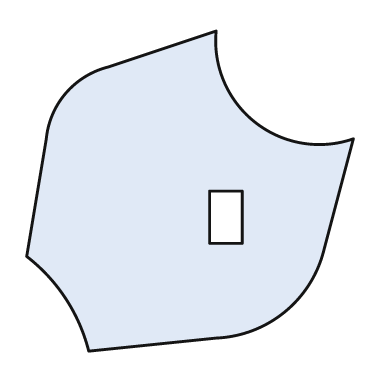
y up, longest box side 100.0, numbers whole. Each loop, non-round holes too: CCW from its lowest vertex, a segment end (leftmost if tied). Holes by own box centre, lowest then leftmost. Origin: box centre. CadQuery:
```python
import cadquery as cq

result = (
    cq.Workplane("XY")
    .moveTo(-31.0, -49.0)
    .lineTo(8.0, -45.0)
    .threePointArc((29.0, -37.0), (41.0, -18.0))
    .lineTo(50.0, 16.0)
    .threePointArc((20.0, 21.0), (8.0, 49.0))
    .lineTo(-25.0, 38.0)
    .threePointArc((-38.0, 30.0), (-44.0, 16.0))
    .lineTo(-50.0, -20.0)
    .threePointArc((-38.0, -33.0), (-31.0, -49.0))
    .close()
    .moveTo(6.0, -16.0)
    .lineTo(16.0, -16.0)
    .lineTo(16.0, 0.0)
    .lineTo(6.0, 0.0)
    .close()
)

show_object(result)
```